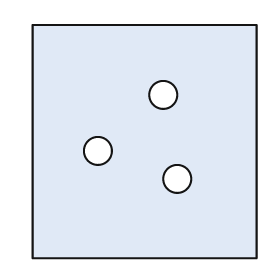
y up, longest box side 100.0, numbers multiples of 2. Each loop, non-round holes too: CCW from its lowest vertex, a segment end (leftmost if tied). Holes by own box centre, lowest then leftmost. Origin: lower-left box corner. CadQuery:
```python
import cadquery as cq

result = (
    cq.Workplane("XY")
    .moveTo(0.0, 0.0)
    .lineTo(96.0, 0.0)
    .lineTo(96.0, 100.0)
    .lineTo(0.0, 100.0)
    .close()
    .moveTo(62.0, 34.0)
    .circle(6.0)
    .moveTo(28.0, 46.0)
    .circle(6.0)
    .moveTo(56.0, 70.0)
    .circle(6.0)
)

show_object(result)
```